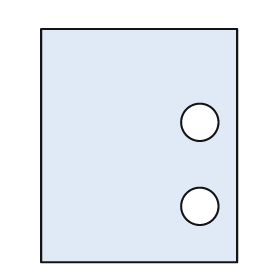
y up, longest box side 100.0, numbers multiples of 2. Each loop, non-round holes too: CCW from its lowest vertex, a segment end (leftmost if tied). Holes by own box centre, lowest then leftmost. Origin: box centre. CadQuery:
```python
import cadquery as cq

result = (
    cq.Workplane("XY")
    .moveTo(-42.0, -50.0)
    .lineTo(42.0, -50.0)
    .lineTo(42.0, 50.0)
    .lineTo(-42.0, 50.0)
    .close()
    .moveTo(26.0, -26.0)
    .circle(8.0)
    .moveTo(26.0, 10.0)
    .circle(8.0)
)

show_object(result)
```